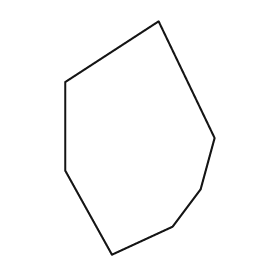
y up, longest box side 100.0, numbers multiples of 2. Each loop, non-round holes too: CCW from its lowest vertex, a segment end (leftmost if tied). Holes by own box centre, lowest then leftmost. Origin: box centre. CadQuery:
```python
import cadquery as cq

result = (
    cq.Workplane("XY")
    .moveTo(-12.0, -50.0)
    .lineTo(14.0, -38.0)
    .lineTo(26.0, -22.0)
    .lineTo(32.0, 0.0)
    .lineTo(8.0, 50.0)
    .lineTo(-32.0, 24.0)
    .lineTo(-32.0, -14.0)
    .close()
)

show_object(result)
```